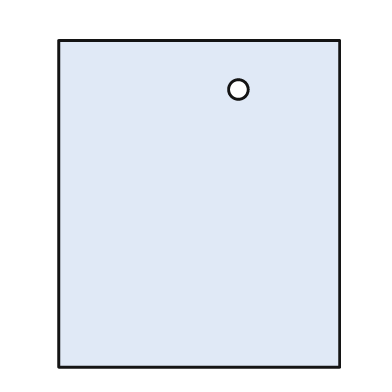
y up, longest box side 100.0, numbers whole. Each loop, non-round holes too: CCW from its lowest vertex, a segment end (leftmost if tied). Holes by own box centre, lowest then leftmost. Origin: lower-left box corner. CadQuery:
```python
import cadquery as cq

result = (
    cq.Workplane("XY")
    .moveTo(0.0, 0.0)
    .lineTo(86.0, 0.0)
    .lineTo(86.0, 100.0)
    .lineTo(0.0, 100.0)
    .close()
    .moveTo(55.0, 85.0)
    .circle(3.0)
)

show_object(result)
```